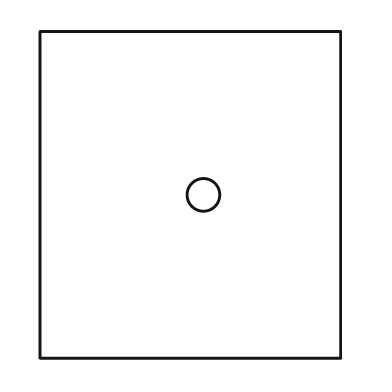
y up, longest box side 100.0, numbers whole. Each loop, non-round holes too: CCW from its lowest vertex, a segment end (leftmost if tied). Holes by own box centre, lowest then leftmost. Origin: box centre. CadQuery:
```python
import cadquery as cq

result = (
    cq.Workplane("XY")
    .moveTo(-46.0, -50.0)
    .lineTo(46.0, -50.0)
    .lineTo(46.0, 50.0)
    .lineTo(-46.0, 50.0)
    .close()
    .moveTo(4.0, 0.0)
    .circle(5.0)
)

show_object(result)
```